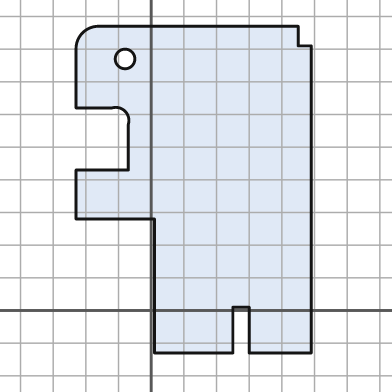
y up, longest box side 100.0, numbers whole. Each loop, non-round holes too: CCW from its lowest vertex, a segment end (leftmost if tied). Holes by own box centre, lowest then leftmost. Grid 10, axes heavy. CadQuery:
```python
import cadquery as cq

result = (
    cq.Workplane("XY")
    .moveTo(1.0, -13.0)
    .lineTo(25.0, -13.0)
    .lineTo(25.0, 1.0)
    .lineTo(30.0, 1.0)
    .lineTo(30.0, -13.0)
    .lineTo(49.0, -13.0)
    .lineTo(49.0, 81.0)
    .lineTo(45.0, 81.0)
    .lineTo(45.0, 87.0)
    .lineTo(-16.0, 87.0)
    .threePointArc((-21.0, 85.0), (-23.0, 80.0))
    .lineTo(-23.0, 62.0)
    .lineTo(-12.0, 62.0)
    .threePointArc((-8.0, 61.0), (-7.0, 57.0))
    .lineTo(-7.0, 43.0)
    .lineTo(-23.0, 43.0)
    .lineTo(-23.0, 28.0)
    .lineTo(1.0, 28.0)
    .close()
    .moveTo(-8.0, 77.0)
    .circle(3.0)
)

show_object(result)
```